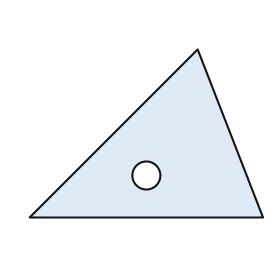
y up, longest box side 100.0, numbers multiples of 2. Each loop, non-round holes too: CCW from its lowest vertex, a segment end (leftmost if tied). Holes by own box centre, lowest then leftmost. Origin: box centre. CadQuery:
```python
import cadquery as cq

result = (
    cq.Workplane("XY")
    .moveTo(-50.0, -36.0)
    .lineTo(50.0, -36.0)
    .lineTo(22.0, 36.0)
    .close()
    .moveTo(0.0, -18.0)
    .circle(6.0)
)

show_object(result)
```